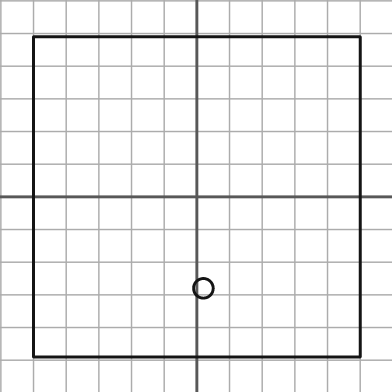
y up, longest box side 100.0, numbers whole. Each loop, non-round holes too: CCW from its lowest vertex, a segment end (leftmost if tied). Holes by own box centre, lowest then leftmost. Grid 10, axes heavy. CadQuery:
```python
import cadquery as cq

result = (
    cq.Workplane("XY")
    .moveTo(-50.0, -49.0)
    .lineTo(50.0, -49.0)
    .lineTo(50.0, 49.0)
    .lineTo(-50.0, 49.0)
    .close()
    .moveTo(2.0, -28.0)
    .circle(3.0)
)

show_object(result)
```